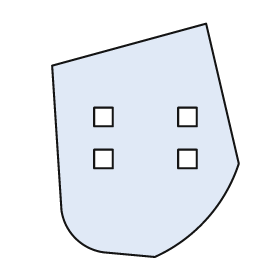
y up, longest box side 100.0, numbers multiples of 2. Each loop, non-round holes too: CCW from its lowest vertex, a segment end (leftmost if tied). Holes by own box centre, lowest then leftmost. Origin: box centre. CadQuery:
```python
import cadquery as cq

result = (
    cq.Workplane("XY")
    .moveTo(4.0, -50.0)
    .threePointArc((26.0, -34.0), (40.0, -10.0))
    .lineTo(26.0, 50.0)
    .lineTo(-40.0, 32.0)
    .lineTo(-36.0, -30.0)
    .threePointArc((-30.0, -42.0), (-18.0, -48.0))
    .close()
    .moveTo(-22.0, -12.0)
    .lineTo(-14.0, -12.0)
    .lineTo(-14.0, -4.0)
    .lineTo(-22.0, -4.0)
    .close()
    .moveTo(14.0, -12.0)
    .lineTo(22.0, -12.0)
    .lineTo(22.0, -4.0)
    .lineTo(14.0, -4.0)
    .close()
    .moveTo(-22.0, 6.0)
    .lineTo(-14.0, 6.0)
    .lineTo(-14.0, 14.0)
    .lineTo(-22.0, 14.0)
    .close()
    .moveTo(14.0, 6.0)
    .lineTo(22.0, 6.0)
    .lineTo(22.0, 14.0)
    .lineTo(14.0, 14.0)
    .close()
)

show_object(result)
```